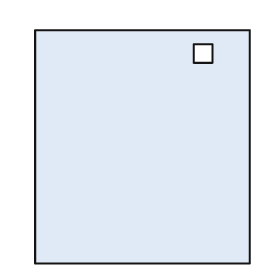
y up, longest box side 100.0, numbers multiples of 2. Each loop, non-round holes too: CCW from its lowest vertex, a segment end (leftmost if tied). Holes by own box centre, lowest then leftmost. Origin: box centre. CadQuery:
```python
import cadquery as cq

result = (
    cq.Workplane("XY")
    .moveTo(-46.0, -50.0)
    .lineTo(46.0, -50.0)
    .lineTo(46.0, 50.0)
    .lineTo(-46.0, 50.0)
    .close()
    .moveTo(22.0, 36.0)
    .lineTo(30.0, 36.0)
    .lineTo(30.0, 44.0)
    .lineTo(22.0, 44.0)
    .close()
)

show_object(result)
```